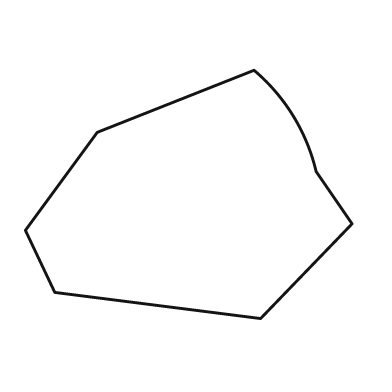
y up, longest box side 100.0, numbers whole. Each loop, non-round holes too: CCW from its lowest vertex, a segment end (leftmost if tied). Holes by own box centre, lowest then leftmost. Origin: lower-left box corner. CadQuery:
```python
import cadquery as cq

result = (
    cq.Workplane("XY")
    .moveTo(72.0, 0.0)
    .lineTo(100.0, 29.0)
    .lineTo(89.0, 45.0)
    .threePointArc((82.0, 62.0), (70.0, 76.0))
    .lineTo(22.0, 57.0)
    .lineTo(0.0, 27.0)
    .lineTo(9.0, 8.0)
    .close()
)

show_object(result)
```